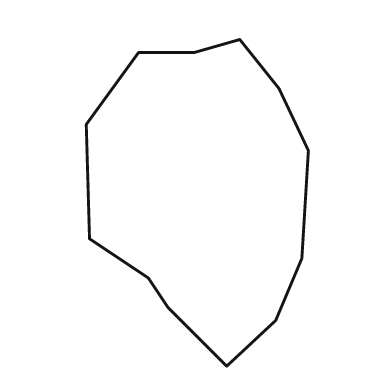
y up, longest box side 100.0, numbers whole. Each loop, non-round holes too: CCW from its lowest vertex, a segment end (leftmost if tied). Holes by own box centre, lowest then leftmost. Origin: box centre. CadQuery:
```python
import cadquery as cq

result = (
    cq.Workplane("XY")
    .moveTo(9.0, -50.0)
    .lineTo(24.0, -36.0)
    .lineTo(32.0, -17.0)
    .lineTo(34.0, 16.0)
    .lineTo(25.0, 35.0)
    .lineTo(13.0, 50.0)
    .lineTo(-1.0, 46.0)
    .lineTo(-18.0, 46.0)
    .lineTo(-34.0, 24.0)
    .lineTo(-33.0, -11.0)
    .lineTo(-15.0, -23.0)
    .lineTo(-9.0, -32.0)
    .close()
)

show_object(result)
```